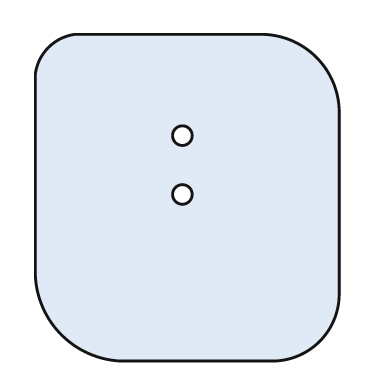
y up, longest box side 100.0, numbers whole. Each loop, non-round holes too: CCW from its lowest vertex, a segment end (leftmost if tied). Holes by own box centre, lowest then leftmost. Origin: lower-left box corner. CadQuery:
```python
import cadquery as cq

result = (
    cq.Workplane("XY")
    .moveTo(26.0, 0.0)
    .lineTo(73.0, 0.0)
    .threePointArc((87.0, 6.0), (93.0, 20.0))
    .lineTo(93.0, 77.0)
    .threePointArc((86.0, 93.0), (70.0, 100.0))
    .lineTo(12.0, 100.0)
    .threePointArc((4.0, 96.0), (0.0, 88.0))
    .lineTo(0.0, 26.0)
    .threePointArc((8.0, 8.0), (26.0, 0.0))
    .close()
    .moveTo(45.0, 51.0)
    .circle(3.0)
    .moveTo(45.0, 69.0)
    .circle(3.0)
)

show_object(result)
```